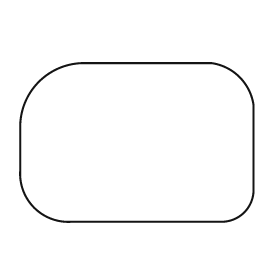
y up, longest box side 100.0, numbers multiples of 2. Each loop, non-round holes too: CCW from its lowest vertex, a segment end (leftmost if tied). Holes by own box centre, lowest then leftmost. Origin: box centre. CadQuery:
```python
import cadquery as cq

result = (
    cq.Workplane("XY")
    .moveTo(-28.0, -34.0)
    .lineTo(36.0, -34.0)
    .threePointArc((46.0, -30.0), (50.0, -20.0))
    .lineTo(50.0, 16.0)
    .threePointArc((44.0, 28.0), (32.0, 34.0))
    .lineTo(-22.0, 34.0)
    .threePointArc((-42.0, 26.0), (-50.0, 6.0))
    .lineTo(-50.0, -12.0)
    .threePointArc((-44.0, -28.0), (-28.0, -34.0))
    .close()
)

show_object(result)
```